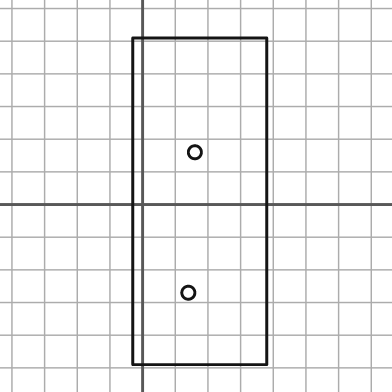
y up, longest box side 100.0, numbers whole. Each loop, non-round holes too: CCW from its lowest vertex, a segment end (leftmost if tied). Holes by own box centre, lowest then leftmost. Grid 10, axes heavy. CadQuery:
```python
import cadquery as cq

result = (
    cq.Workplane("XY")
    .moveTo(-3.0, -49.0)
    .lineTo(38.0, -49.0)
    .lineTo(38.0, 51.0)
    .lineTo(-3.0, 51.0)
    .close()
    .moveTo(14.0, -27.0)
    .circle(2.0)
    .moveTo(16.0, 16.0)
    .circle(2.0)
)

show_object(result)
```